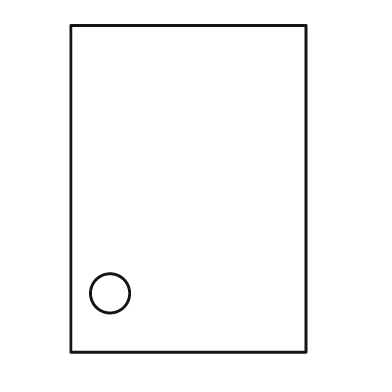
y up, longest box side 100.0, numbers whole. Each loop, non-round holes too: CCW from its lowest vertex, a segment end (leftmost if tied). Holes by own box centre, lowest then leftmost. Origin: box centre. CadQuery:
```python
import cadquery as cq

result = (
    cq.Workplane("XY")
    .moveTo(-36.0, -50.0)
    .lineTo(36.0, -50.0)
    .lineTo(36.0, 50.0)
    .lineTo(-36.0, 50.0)
    .close()
    .moveTo(-24.0, -32.0)
    .circle(6.0)
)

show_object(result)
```